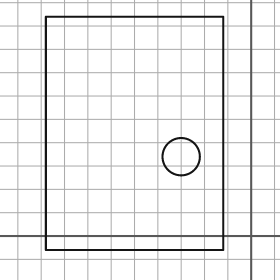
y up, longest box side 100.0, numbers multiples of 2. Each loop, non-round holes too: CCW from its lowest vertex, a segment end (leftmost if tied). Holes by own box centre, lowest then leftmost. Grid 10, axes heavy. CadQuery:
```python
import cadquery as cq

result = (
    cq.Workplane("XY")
    .moveTo(-88.0, -6.0)
    .lineTo(-12.0, -6.0)
    .lineTo(-12.0, 94.0)
    .lineTo(-88.0, 94.0)
    .close()
    .moveTo(-30.0, 34.0)
    .circle(8.0)
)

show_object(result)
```